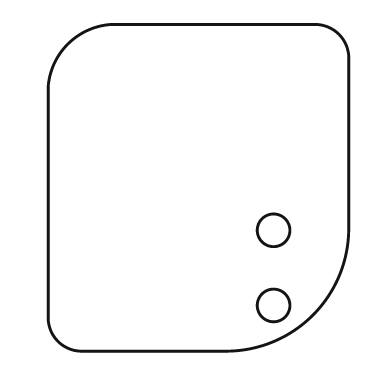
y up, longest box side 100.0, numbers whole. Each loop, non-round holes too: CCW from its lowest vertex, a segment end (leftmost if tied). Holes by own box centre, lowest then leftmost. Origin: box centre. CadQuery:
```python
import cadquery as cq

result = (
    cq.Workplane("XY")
    .moveTo(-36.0, -50.0)
    .lineTo(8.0, -50.0)
    .threePointArc((35.0, -39.0), (46.0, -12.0))
    .lineTo(46.0, 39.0)
    .threePointArc((43.0, 47.0), (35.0, 50.0))
    .lineTo(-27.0, 50.0)
    .threePointArc((-40.0, 44.0), (-46.0, 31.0))
    .lineTo(-46.0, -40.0)
    .threePointArc((-43.0, -47.0), (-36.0, -50.0))
    .close()
    .moveTo(23.0, -36.0)
    .circle(5.0)
    .moveTo(23.0, -13.0)
    .circle(5.0)
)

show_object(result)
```